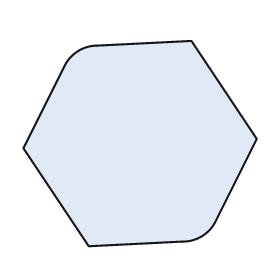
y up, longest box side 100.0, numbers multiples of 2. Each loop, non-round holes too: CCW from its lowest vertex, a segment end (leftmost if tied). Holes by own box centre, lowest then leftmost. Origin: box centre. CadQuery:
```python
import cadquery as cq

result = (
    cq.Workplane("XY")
    .moveTo(-22.0, -44.0)
    .lineTo(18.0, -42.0)
    .threePointArc((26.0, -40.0), (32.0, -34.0))
    .lineTo(50.0, 2.0)
    .lineTo(22.0, 44.0)
    .lineTo(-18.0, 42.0)
    .threePointArc((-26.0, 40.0), (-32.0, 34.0))
    .lineTo(-50.0, -2.0)
    .close()
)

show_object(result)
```